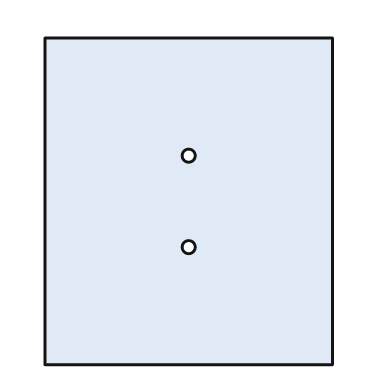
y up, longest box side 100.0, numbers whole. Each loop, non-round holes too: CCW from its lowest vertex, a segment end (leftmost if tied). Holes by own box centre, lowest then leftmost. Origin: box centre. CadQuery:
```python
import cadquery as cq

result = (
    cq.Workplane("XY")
    .moveTo(-44.0, -50.0)
    .lineTo(44.0, -50.0)
    .lineTo(44.0, 50.0)
    .lineTo(-44.0, 50.0)
    .close()
    .moveTo(0.0, -14.0)
    .circle(2.0)
    .moveTo(0.0, 14.0)
    .circle(2.0)
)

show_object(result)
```